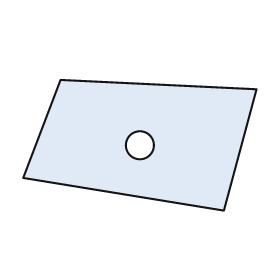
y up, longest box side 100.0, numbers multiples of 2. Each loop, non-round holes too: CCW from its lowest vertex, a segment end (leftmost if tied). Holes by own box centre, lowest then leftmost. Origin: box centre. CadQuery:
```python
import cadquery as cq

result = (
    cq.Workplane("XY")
    .moveTo(36.0, -28.0)
    .lineTo(50.0, 24.0)
    .lineTo(-34.0, 28.0)
    .lineTo(-50.0, -14.0)
    .close()
    .moveTo(0.0, 0.0)
    .circle(6.0)
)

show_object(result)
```